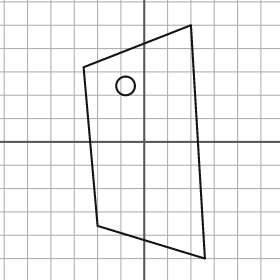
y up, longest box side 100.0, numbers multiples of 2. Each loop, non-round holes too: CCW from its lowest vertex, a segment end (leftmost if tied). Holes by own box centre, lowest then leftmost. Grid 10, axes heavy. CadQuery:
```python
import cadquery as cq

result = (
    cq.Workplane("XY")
    .moveTo(26.0, -50.0)
    .lineTo(20.0, 50.0)
    .lineTo(-26.0, 32.0)
    .lineTo(-20.0, -36.0)
    .close()
    .moveTo(-8.0, 24.0)
    .circle(4.0)
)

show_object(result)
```